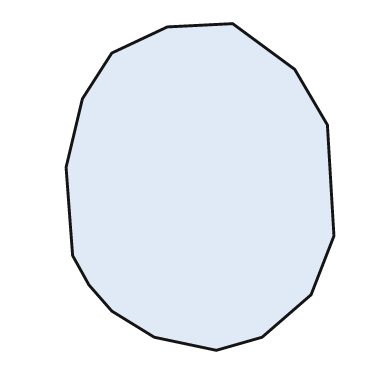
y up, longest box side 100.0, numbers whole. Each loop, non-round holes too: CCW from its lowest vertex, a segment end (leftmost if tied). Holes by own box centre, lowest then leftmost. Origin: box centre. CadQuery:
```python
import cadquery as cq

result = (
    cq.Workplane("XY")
    .moveTo(5.0, -50.0)
    .lineTo(19.0, -46.0)
    .lineTo(34.0, -33.0)
    .lineTo(41.0, -15.0)
    .lineTo(39.0, 19.0)
    .lineTo(29.0, 36.0)
    .lineTo(10.0, 50.0)
    .lineTo(-10.0, 49.0)
    .lineTo(-27.0, 41.0)
    .lineTo(-36.0, 27.0)
    .lineTo(-41.0, 6.0)
    .lineTo(-39.0, -21.0)
    .lineTo(-34.0, -30.0)
    .lineTo(-27.0, -38.0)
    .lineTo(-14.0, -46.0)
    .close()
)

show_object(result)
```